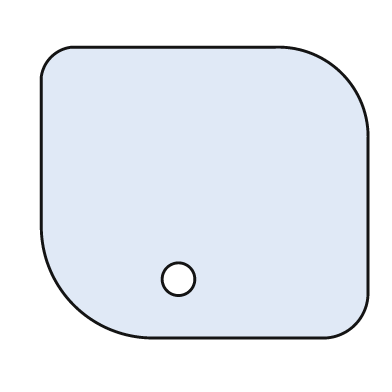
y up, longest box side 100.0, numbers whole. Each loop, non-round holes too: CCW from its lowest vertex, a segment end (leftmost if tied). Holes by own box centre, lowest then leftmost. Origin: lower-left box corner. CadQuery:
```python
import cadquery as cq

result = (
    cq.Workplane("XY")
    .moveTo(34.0, 0.0)
    .lineTo(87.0, 0.0)
    .threePointArc((96.0, 4.0), (100.0, 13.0))
    .lineTo(100.0, 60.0)
    .threePointArc((92.0, 81.0), (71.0, 89.0))
    .lineTo(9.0, 89.0)
    .threePointArc((3.0, 86.0), (0.0, 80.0))
    .lineTo(0.0, 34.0)
    .threePointArc((10.0, 10.0), (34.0, 0.0))
    .close()
    .moveTo(42.0, 18.0)
    .circle(5.0)
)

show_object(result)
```